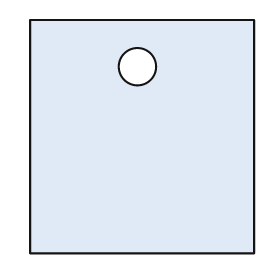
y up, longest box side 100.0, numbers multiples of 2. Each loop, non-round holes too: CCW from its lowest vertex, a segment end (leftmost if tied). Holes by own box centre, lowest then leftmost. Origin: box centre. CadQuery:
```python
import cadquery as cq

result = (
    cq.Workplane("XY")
    .moveTo(-48.0, -50.0)
    .lineTo(48.0, -50.0)
    .lineTo(48.0, 50.0)
    .lineTo(-48.0, 50.0)
    .close()
    .moveTo(-2.0, 30.0)
    .circle(8.0)
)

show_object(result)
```